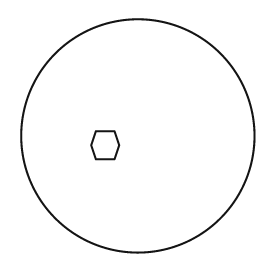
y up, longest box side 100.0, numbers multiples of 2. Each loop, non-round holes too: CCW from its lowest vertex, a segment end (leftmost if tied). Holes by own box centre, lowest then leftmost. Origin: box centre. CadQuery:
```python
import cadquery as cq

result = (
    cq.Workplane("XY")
    .moveTo(0.0, 0.0)
    .circle(50.0)
    .moveTo(-18.0, -10.0)
    .lineTo(-10.0, -10.0)
    .lineTo(-8.0, -4.0)
    .lineTo(-10.0, 2.0)
    .lineTo(-18.0, 2.0)
    .lineTo(-20.0, -4.0)
    .close()
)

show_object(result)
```